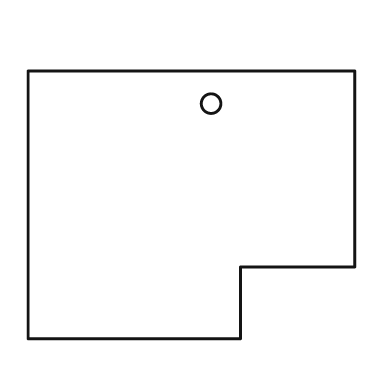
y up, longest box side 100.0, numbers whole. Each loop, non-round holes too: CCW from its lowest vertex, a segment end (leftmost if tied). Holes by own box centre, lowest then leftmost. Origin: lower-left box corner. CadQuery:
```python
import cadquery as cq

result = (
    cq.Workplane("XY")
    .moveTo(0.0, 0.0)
    .lineTo(65.0, 0.0)
    .lineTo(65.0, 22.0)
    .lineTo(100.0, 22.0)
    .lineTo(100.0, 82.0)
    .lineTo(0.0, 82.0)
    .close()
    .moveTo(56.0, 72.0)
    .circle(3.0)
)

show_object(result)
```